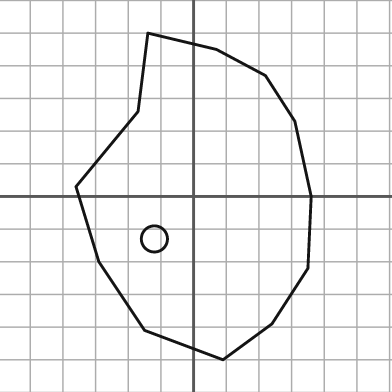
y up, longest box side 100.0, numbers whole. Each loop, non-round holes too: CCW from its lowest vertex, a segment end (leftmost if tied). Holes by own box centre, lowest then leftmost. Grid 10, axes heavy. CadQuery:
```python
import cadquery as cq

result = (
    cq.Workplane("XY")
    .moveTo(9.0, -50.0)
    .lineTo(24.0, -39.0)
    .lineTo(35.0, -22.0)
    .lineTo(36.0, 0.0)
    .lineTo(31.0, 23.0)
    .lineTo(22.0, 37.0)
    .lineTo(7.0, 45.0)
    .lineTo(-14.0, 50.0)
    .lineTo(-17.0, 26.0)
    .lineTo(-36.0, 3.0)
    .lineTo(-29.0, -20.0)
    .lineTo(-15.0, -41.0)
    .close()
    .moveTo(-12.0, -13.0)
    .circle(4.0)
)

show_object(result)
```